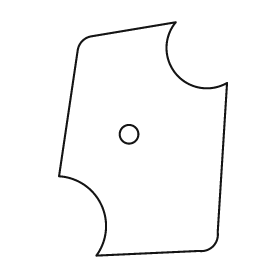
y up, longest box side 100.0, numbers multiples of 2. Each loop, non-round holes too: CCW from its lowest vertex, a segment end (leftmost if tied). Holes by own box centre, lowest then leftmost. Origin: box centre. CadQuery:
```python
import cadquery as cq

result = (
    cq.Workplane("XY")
    .moveTo(-20.0, -50.0)
    .lineTo(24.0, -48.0)
    .threePointArc((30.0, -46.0), (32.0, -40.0))
    .lineTo(36.0, 24.0)
    .threePointArc((14.0, 28.0), (14.0, 50.0))
    .lineTo(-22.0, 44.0)
    .threePointArc((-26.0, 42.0), (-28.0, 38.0))
    .lineTo(-36.0, -16.0)
    .threePointArc((-18.0, -28.0), (-20.0, -50.0))
    .close()
    .moveTo(-6.0, 2.0)
    .circle(4.0)
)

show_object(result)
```